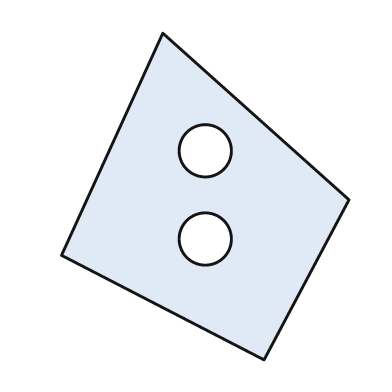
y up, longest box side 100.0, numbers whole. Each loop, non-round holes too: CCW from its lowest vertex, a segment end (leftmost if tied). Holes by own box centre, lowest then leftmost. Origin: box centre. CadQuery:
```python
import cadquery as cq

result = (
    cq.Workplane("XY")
    .moveTo(18.0, -50.0)
    .lineTo(44.0, -1.0)
    .lineTo(-13.0, 50.0)
    .lineTo(-44.0, -18.0)
    .close()
    .moveTo(0.0, -13.0)
    .circle(8.0)
    .moveTo(0.0, 14.0)
    .circle(8.0)
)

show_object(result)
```